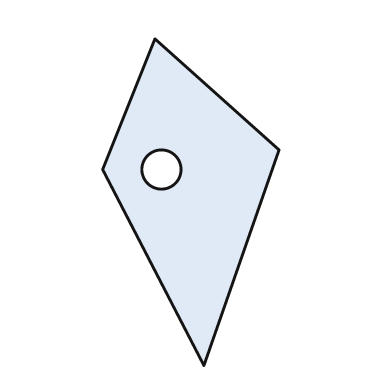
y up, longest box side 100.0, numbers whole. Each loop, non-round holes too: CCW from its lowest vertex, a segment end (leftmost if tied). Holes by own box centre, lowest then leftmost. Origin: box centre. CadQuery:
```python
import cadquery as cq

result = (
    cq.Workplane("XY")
    .moveTo(4.0, -50.0)
    .lineTo(27.0, 16.0)
    .lineTo(-11.0, 50.0)
    .lineTo(-27.0, 10.0)
    .close()
    .moveTo(-9.0, 10.0)
    .circle(6.0)
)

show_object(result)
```